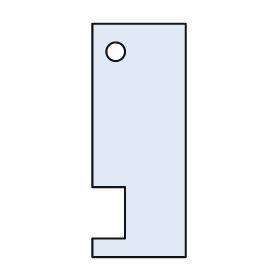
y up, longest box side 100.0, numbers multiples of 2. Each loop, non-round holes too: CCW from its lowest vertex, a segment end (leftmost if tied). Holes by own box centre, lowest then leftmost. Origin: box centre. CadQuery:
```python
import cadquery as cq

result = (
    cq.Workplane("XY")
    .moveTo(-20.0, -50.0)
    .lineTo(20.0, -50.0)
    .lineTo(20.0, 50.0)
    .lineTo(-20.0, 50.0)
    .lineTo(-20.0, -20.0)
    .lineTo(-6.0, -20.0)
    .lineTo(-6.0, -42.0)
    .lineTo(-20.0, -42.0)
    .close()
    .moveTo(-10.0, 38.0)
    .circle(4.0)
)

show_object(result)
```